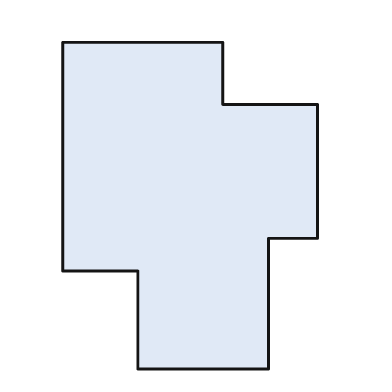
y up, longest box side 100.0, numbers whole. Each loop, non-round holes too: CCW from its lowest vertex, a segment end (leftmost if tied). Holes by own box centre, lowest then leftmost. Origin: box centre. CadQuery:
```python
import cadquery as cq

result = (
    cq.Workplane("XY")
    .moveTo(-16.0, -50.0)
    .lineTo(24.0, -50.0)
    .lineTo(24.0, -10.0)
    .lineTo(39.0, -10.0)
    .lineTo(39.0, 31.0)
    .lineTo(10.0, 31.0)
    .lineTo(10.0, 50.0)
    .lineTo(-39.0, 50.0)
    .lineTo(-39.0, -20.0)
    .lineTo(-16.0, -20.0)
    .close()
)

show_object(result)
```